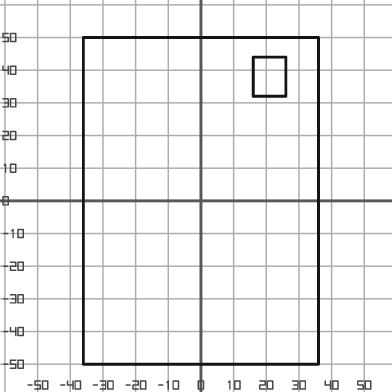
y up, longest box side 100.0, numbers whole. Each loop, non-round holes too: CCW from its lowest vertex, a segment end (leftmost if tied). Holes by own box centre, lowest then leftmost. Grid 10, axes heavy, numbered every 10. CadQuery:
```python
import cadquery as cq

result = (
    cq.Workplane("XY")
    .moveTo(-36.0, -50.0)
    .lineTo(36.0, -50.0)
    .lineTo(36.0, 50.0)
    .lineTo(-36.0, 50.0)
    .close()
    .moveTo(16.0, 32.0)
    .lineTo(26.0, 32.0)
    .lineTo(26.0, 44.0)
    .lineTo(16.0, 44.0)
    .close()
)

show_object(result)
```